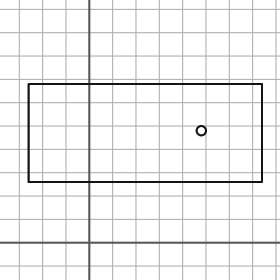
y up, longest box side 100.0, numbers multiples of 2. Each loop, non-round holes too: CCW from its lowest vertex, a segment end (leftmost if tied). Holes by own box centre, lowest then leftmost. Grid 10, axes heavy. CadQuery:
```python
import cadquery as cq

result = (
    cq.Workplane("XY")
    .moveTo(-26.0, 26.0)
    .lineTo(74.0, 26.0)
    .lineTo(74.0, 68.0)
    .lineTo(-26.0, 68.0)
    .close()
    .moveTo(48.0, 48.0)
    .circle(2.0)
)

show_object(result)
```